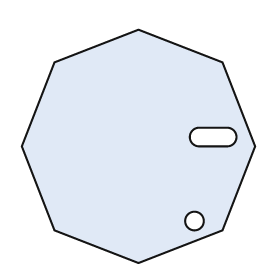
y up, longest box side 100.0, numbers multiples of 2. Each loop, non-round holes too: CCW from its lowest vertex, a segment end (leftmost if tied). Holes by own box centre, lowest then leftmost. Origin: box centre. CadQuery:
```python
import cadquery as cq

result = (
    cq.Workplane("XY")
    .moveTo(0.0, -50.0)
    .lineTo(36.0, -36.0)
    .lineTo(50.0, 0.0)
    .lineTo(36.0, 36.0)
    .lineTo(0.0, 50.0)
    .lineTo(-36.0, 36.0)
    .lineTo(-50.0, 0.0)
    .lineTo(-36.0, -36.0)
    .close()
    .moveTo(24.0, -32.0)
    .circle(4.0)
    .moveTo(26.0, 0.0)
    .lineTo(38.0, 0.0)
    .threePointArc((42.0, 4.0), (38.0, 8.0))
    .lineTo(26.0, 8.0)
    .threePointArc((22.0, 4.0), (26.0, 0.0))
    .close()
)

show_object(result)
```